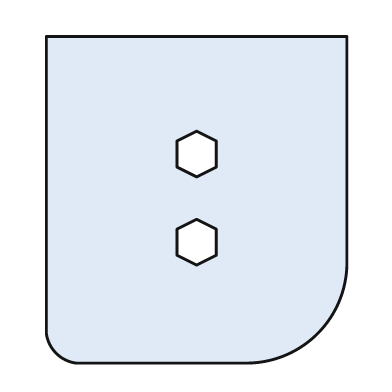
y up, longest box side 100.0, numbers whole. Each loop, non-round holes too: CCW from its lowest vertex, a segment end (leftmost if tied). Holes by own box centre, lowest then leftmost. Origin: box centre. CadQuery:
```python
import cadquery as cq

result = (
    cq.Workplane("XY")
    .moveTo(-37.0, -50.0)
    .lineTo(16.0, -50.0)
    .threePointArc((37.0, -41.0), (46.0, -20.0))
    .lineTo(46.0, 50.0)
    .lineTo(-46.0, 50.0)
    .lineTo(-46.0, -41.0)
    .threePointArc((-43.0, -47.0), (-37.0, -50.0))
    .close()
    .moveTo(0.0, -20.0)
    .lineTo(6.0, -17.0)
    .lineTo(6.0, -9.0)
    .lineTo(0.0, -6.0)
    .lineTo(-6.0, -9.0)
    .lineTo(-6.0, -17.0)
    .close()
    .moveTo(0.0, 7.0)
    .lineTo(6.0, 10.0)
    .lineTo(6.0, 18.0)
    .lineTo(0.0, 21.0)
    .lineTo(-6.0, 18.0)
    .lineTo(-6.0, 10.0)
    .close()
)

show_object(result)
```